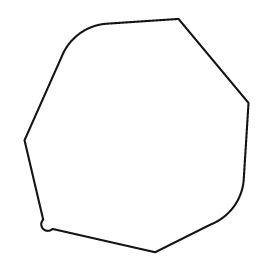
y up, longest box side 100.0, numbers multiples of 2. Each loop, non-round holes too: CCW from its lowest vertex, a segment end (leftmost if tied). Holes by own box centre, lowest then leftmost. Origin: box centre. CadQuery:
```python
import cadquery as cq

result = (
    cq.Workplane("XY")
    .moveTo(8.0, -50.0)
    .lineTo(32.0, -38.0)
    .threePointArc((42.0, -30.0), (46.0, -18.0))
    .lineTo(48.0, 14.0)
    .lineTo(18.0, 50.0)
    .lineTo(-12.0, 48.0)
    .threePointArc((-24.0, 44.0), (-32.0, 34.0))
    .lineTo(-48.0, -2.0)
    .lineTo(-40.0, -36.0)
    .threePointArc((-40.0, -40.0), (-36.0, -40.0))
    .close()
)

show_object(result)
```